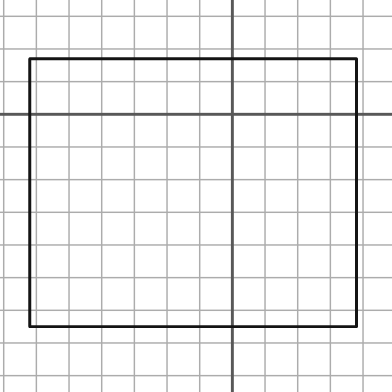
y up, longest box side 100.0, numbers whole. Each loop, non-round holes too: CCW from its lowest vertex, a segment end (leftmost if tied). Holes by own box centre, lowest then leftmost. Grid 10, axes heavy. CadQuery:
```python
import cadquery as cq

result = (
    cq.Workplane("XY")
    .moveTo(-62.0, -65.0)
    .lineTo(38.0, -65.0)
    .lineTo(38.0, 17.0)
    .lineTo(-62.0, 17.0)
    .close()
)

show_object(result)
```